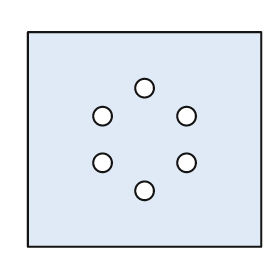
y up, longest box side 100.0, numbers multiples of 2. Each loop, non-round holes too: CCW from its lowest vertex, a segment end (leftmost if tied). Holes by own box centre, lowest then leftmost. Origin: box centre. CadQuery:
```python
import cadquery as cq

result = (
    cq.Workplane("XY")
    .moveTo(-50.0, -46.0)
    .lineTo(50.0, -46.0)
    .lineTo(50.0, 46.0)
    .lineTo(-50.0, 46.0)
    .close()
    .moveTo(0.0, -22.0)
    .circle(4.0)
    .moveTo(-18.0, -10.0)
    .circle(4.0)
    .moveTo(18.0, -10.0)
    .circle(4.0)
    .moveTo(-18.0, 10.0)
    .circle(4.0)
    .moveTo(18.0, 10.0)
    .circle(4.0)
    .moveTo(0.0, 22.0)
    .circle(4.0)
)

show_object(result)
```